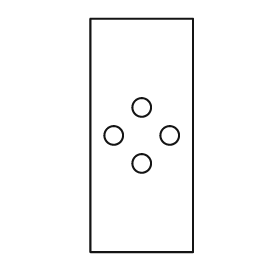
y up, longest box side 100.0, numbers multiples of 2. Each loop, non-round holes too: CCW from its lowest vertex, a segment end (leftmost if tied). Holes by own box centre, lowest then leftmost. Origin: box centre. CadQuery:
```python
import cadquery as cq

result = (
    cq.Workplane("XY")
    .moveTo(-22.0, -50.0)
    .lineTo(22.0, -50.0)
    .lineTo(22.0, 50.0)
    .lineTo(-22.0, 50.0)
    .close()
    .moveTo(0.0, -12.0)
    .circle(4.0)
    .moveTo(-12.0, 0.0)
    .circle(4.0)
    .moveTo(12.0, 0.0)
    .circle(4.0)
    .moveTo(0.0, 12.0)
    .circle(4.0)
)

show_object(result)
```